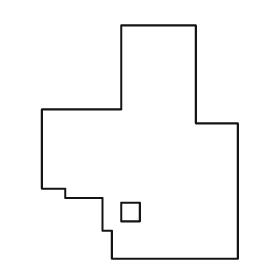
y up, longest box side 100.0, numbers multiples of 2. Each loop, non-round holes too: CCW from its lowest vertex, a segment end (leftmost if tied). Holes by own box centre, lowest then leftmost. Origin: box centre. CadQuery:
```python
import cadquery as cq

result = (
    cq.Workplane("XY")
    .moveTo(-12.0, -50.0)
    .lineTo(42.0, -50.0)
    .lineTo(42.0, 8.0)
    .lineTo(24.0, 8.0)
    .lineTo(24.0, 50.0)
    .lineTo(-8.0, 50.0)
    .lineTo(-8.0, 14.0)
    .lineTo(-42.0, 14.0)
    .lineTo(-42.0, -20.0)
    .lineTo(-32.0, -20.0)
    .lineTo(-32.0, -24.0)
    .lineTo(-16.0, -24.0)
    .lineTo(-16.0, -38.0)
    .lineTo(-12.0, -38.0)
    .close()
    .moveTo(-8.0, -34.0)
    .lineTo(0.0, -34.0)
    .lineTo(0.0, -26.0)
    .lineTo(-8.0, -26.0)
    .close()
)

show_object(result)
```